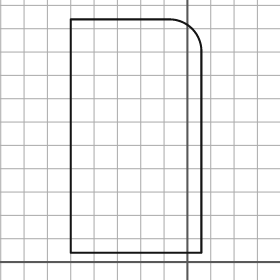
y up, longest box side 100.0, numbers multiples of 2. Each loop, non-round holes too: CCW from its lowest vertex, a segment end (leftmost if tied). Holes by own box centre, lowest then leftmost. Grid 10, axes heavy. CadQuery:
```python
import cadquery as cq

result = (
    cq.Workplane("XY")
    .moveTo(-50.0, 4.0)
    .lineTo(6.0, 4.0)
    .lineTo(6.0, 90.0)
    .threePointArc((2.0, 100.0), (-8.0, 104.0))
    .lineTo(-50.0, 104.0)
    .close()
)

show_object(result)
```